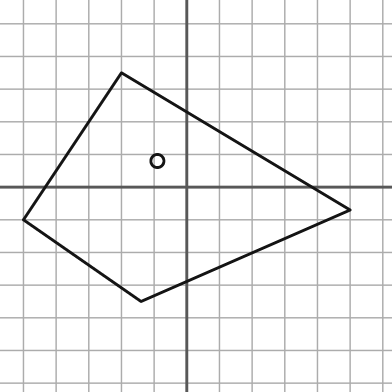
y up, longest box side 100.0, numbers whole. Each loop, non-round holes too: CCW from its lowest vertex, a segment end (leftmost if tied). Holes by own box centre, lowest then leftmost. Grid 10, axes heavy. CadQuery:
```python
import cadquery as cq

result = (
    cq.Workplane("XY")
    .moveTo(-14.0, -35.0)
    .lineTo(50.0, -7.0)
    .lineTo(-20.0, 35.0)
    .lineTo(-50.0, -10.0)
    .close()
    .moveTo(-9.0, 8.0)
    .circle(2.0)
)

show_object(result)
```